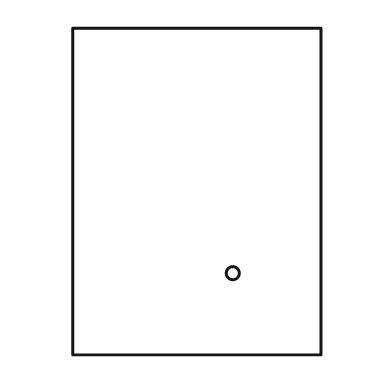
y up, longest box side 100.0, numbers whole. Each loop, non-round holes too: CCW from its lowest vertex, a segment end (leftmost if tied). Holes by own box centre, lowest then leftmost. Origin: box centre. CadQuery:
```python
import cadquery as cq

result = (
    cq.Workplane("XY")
    .moveTo(-38.0, -50.0)
    .lineTo(38.0, -50.0)
    .lineTo(38.0, 50.0)
    .lineTo(-38.0, 50.0)
    .close()
    .moveTo(11.0, -25.0)
    .circle(2.0)
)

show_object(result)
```